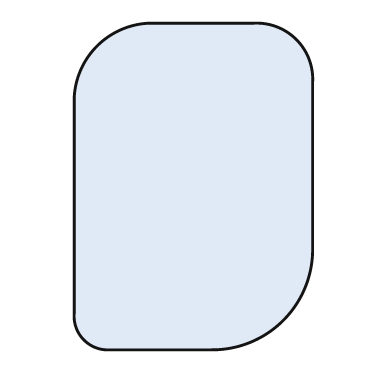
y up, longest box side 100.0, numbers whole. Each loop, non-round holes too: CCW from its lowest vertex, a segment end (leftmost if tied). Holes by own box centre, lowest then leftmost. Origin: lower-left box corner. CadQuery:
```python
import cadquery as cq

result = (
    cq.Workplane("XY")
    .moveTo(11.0, 0.0)
    .lineTo(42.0, 0.0)
    .threePointArc((64.0, 9.0), (73.0, 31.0))
    .lineTo(73.0, 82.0)
    .threePointArc((68.0, 95.0), (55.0, 100.0))
    .lineTo(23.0, 100.0)
    .threePointArc((7.0, 93.0), (0.0, 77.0))
    .lineTo(0.0, 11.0)
    .threePointArc((3.0, 3.0), (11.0, 0.0))
    .close()
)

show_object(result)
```